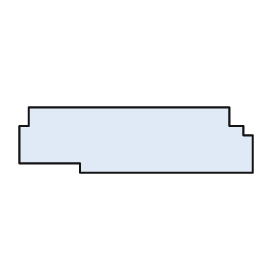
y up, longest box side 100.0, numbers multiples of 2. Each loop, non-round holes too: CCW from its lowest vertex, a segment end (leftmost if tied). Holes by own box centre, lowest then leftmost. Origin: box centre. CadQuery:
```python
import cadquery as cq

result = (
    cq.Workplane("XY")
    .moveTo(-24.0, -14.0)
    .lineTo(50.0, -14.0)
    .lineTo(50.0, 2.0)
    .lineTo(46.0, 2.0)
    .lineTo(46.0, 6.0)
    .lineTo(40.0, 6.0)
    .lineTo(40.0, 14.0)
    .lineTo(-46.0, 14.0)
    .lineTo(-46.0, 6.0)
    .lineTo(-50.0, 6.0)
    .lineTo(-50.0, -10.0)
    .lineTo(-24.0, -10.0)
    .close()
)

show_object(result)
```